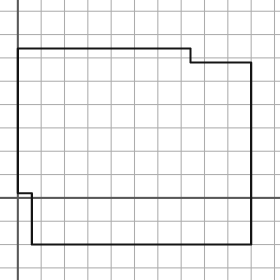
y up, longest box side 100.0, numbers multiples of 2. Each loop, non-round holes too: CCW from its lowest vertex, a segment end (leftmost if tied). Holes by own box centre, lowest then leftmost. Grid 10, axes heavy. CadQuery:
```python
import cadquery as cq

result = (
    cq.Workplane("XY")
    .moveTo(6.0, -20.0)
    .lineTo(100.0, -20.0)
    .lineTo(100.0, 58.0)
    .lineTo(74.0, 58.0)
    .lineTo(74.0, 64.0)
    .lineTo(0.0, 64.0)
    .lineTo(0.0, 2.0)
    .lineTo(6.0, 2.0)
    .close()
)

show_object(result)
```